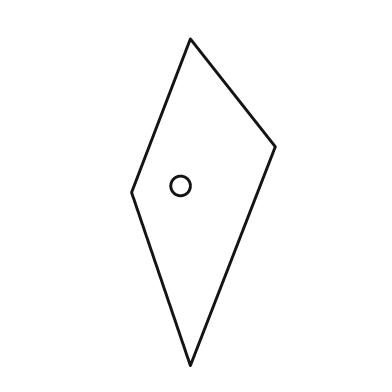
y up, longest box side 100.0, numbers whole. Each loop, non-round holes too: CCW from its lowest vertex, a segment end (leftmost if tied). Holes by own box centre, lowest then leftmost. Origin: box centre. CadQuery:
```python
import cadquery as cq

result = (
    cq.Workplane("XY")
    .moveTo(-4.0, -50.0)
    .lineTo(22.0, 17.0)
    .lineTo(-4.0, 50.0)
    .lineTo(-22.0, 3.0)
    .close()
    .moveTo(-7.0, 5.0)
    .circle(3.0)
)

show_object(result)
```